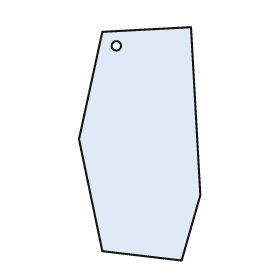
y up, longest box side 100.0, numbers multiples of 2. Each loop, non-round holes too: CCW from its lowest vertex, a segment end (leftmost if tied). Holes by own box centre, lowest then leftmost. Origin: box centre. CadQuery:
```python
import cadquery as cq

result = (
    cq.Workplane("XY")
    .moveTo(18.0, -50.0)
    .lineTo(26.0, -22.0)
    .lineTo(22.0, 50.0)
    .lineTo(-16.0, 48.0)
    .lineTo(-26.0, 2.0)
    .lineTo(-16.0, -46.0)
    .close()
    .moveTo(-10.0, 42.0)
    .circle(2.0)
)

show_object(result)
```